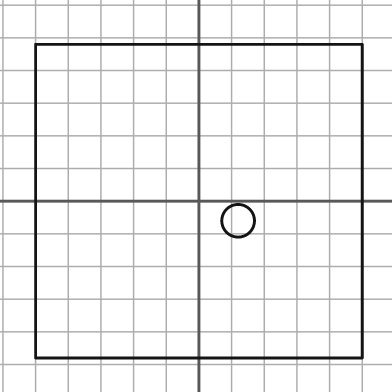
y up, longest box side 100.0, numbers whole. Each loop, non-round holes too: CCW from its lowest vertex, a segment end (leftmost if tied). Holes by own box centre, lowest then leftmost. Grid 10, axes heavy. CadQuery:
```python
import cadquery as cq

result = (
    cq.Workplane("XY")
    .moveTo(-50.0, -48.0)
    .lineTo(50.0, -48.0)
    .lineTo(50.0, 48.0)
    .lineTo(-50.0, 48.0)
    .close()
    .moveTo(12.0, -6.0)
    .circle(5.0)
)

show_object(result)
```